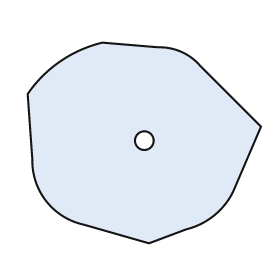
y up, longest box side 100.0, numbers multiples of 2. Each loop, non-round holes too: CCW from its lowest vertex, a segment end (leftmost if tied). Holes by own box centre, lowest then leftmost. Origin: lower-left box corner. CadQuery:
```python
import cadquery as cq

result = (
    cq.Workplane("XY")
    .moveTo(52.0, 0.0)
    .lineTo(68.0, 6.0)
    .threePointArc((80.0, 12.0), (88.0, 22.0))
    .lineTo(100.0, 50.0)
    .lineTo(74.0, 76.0)
    .threePointArc((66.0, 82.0), (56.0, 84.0))
    .lineTo(32.0, 86.0)
    .threePointArc((14.0, 78.0), (0.0, 64.0))
    .lineTo(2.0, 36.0)
    .threePointArc((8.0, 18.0), (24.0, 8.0))
    .close()
    .moveTo(50.0, 44.0)
    .circle(4.0)
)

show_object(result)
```